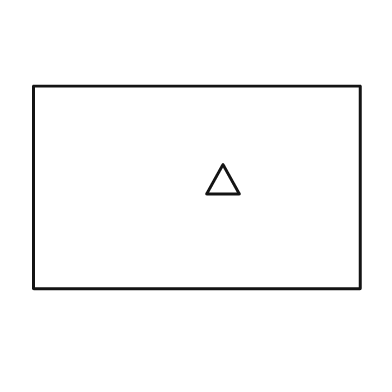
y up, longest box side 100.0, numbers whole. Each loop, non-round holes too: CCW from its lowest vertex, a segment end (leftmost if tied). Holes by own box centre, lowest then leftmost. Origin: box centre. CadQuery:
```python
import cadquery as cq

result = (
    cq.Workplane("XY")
    .moveTo(-50.0, -31.0)
    .lineTo(50.0, -31.0)
    .lineTo(50.0, 31.0)
    .lineTo(-50.0, 31.0)
    .close()
    .moveTo(3.0, -2.0)
    .lineTo(13.0, -2.0)
    .lineTo(8.0, 7.0)
    .close()
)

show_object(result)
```